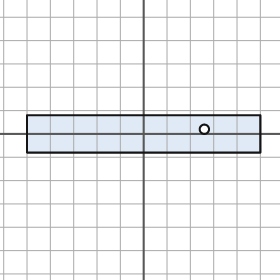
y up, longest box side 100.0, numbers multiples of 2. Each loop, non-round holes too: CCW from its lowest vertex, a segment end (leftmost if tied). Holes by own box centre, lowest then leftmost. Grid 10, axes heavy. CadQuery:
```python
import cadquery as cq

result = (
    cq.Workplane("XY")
    .moveTo(-50.0, -8.0)
    .lineTo(50.0, -8.0)
    .lineTo(50.0, 8.0)
    .lineTo(-50.0, 8.0)
    .close()
    .moveTo(26.0, 2.0)
    .circle(2.0)
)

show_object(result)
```